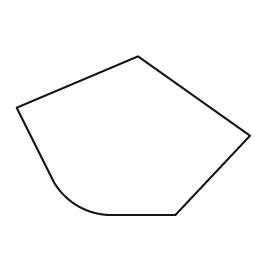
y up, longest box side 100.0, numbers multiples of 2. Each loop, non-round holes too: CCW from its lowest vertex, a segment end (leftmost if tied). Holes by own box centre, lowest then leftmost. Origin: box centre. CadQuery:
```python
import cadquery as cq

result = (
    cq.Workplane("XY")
    .moveTo(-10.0, -34.0)
    .lineTo(18.0, -34.0)
    .lineTo(50.0, 0.0)
    .lineTo(2.0, 34.0)
    .lineTo(-50.0, 12.0)
    .lineTo(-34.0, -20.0)
    .threePointArc((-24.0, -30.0), (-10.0, -34.0))
    .close()
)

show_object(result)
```